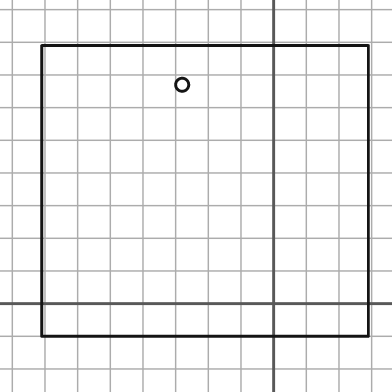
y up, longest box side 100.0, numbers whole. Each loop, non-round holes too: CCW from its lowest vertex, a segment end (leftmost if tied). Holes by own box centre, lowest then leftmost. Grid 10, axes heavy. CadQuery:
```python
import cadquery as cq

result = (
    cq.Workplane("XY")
    .moveTo(-71.0, -10.0)
    .lineTo(29.0, -10.0)
    .lineTo(29.0, 79.0)
    .lineTo(-71.0, 79.0)
    .close()
    .moveTo(-28.0, 67.0)
    .circle(2.0)
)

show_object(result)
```